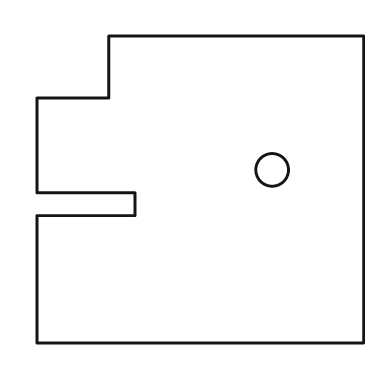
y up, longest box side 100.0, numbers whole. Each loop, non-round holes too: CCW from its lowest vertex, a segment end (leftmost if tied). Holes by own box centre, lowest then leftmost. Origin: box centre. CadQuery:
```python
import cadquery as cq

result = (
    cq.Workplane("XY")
    .moveTo(-50.0, -47.0)
    .lineTo(50.0, -47.0)
    .lineTo(50.0, 47.0)
    .lineTo(-28.0, 47.0)
    .lineTo(-28.0, 28.0)
    .lineTo(-50.0, 28.0)
    .lineTo(-50.0, -1.0)
    .lineTo(-20.0, -1.0)
    .lineTo(-20.0, -8.0)
    .lineTo(-50.0, -8.0)
    .close()
    .moveTo(22.0, 6.0)
    .circle(5.0)
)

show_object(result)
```